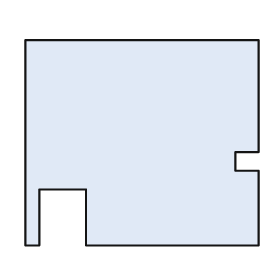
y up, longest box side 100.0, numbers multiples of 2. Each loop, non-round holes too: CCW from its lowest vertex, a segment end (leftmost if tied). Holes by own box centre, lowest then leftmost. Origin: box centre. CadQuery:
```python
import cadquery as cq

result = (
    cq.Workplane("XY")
    .moveTo(-50.0, -44.0)
    .lineTo(-44.0, -44.0)
    .lineTo(-44.0, -20.0)
    .lineTo(-24.0, -20.0)
    .lineTo(-24.0, -44.0)
    .lineTo(50.0, -44.0)
    .lineTo(50.0, -12.0)
    .lineTo(40.0, -12.0)
    .lineTo(40.0, -4.0)
    .lineTo(50.0, -4.0)
    .lineTo(50.0, 44.0)
    .lineTo(-50.0, 44.0)
    .close()
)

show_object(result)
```